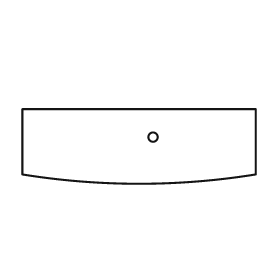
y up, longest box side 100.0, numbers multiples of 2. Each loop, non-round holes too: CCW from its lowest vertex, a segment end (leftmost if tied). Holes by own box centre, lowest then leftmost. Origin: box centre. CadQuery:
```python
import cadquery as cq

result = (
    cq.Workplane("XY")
    .moveTo(-50.0, -12.0)
    .threePointArc((0.0, -16.0), (50.0, -12.0))
    .lineTo(50.0, 16.0)
    .lineTo(-50.0, 16.0)
    .close()
    .moveTo(6.0, 4.0)
    .circle(2.0)
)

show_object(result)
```